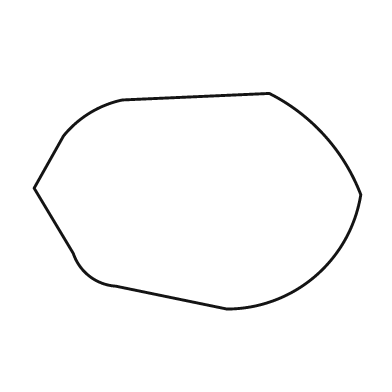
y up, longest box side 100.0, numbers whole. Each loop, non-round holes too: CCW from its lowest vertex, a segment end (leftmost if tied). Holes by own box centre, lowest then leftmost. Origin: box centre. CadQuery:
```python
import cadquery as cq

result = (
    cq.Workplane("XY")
    .moveTo(9.0, -33.0)
    .threePointArc((36.0, -23.0), (50.0, 2.0))
    .threePointArc((39.0, 20.0), (22.0, 33.0))
    .lineTo(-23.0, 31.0)
    .threePointArc((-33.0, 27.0), (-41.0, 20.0))
    .lineTo(-50.0, 4.0)
    .lineTo(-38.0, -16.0)
    .threePointArc((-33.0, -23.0), (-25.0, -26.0))
    .close()
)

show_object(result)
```